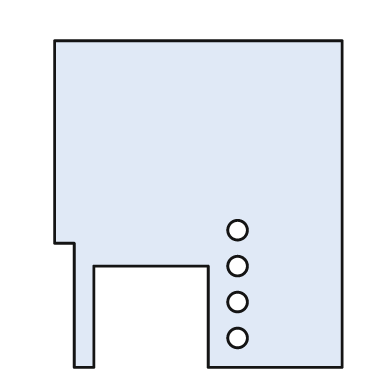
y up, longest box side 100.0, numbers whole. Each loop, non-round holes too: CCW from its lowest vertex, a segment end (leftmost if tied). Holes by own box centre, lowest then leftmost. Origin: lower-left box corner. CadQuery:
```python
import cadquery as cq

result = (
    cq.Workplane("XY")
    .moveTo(6.0, 0.0)
    .lineTo(12.0, 0.0)
    .lineTo(12.0, 31.0)
    .lineTo(47.0, 31.0)
    .lineTo(47.0, 0.0)
    .lineTo(88.0, 0.0)
    .lineTo(88.0, 100.0)
    .lineTo(0.0, 100.0)
    .lineTo(0.0, 38.0)
    .lineTo(6.0, 38.0)
    .close()
    .moveTo(56.0, 9.0)
    .circle(3.0)
    .moveTo(56.0, 20.0)
    .circle(3.0)
    .moveTo(56.0, 31.0)
    .circle(3.0)
    .moveTo(56.0, 42.0)
    .circle(3.0)
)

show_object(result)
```